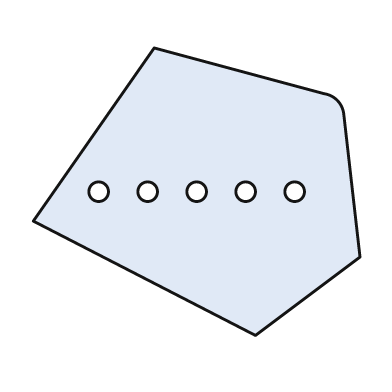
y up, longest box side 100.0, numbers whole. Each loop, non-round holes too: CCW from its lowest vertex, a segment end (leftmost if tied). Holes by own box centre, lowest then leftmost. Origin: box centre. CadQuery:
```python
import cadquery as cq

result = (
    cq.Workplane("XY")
    .moveTo(18.0, -44.0)
    .lineTo(50.0, -20.0)
    .lineTo(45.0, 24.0)
    .threePointArc((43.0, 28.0), (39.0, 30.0))
    .lineTo(-13.0, 44.0)
    .lineTo(-50.0, -9.0)
    .close()
    .moveTo(-30.0, 0.0)
    .circle(3.0)
    .moveTo(-15.0, 0.0)
    .circle(3.0)
    .moveTo(0.0, 0.0)
    .circle(3.0)
    .moveTo(15.0, 0.0)
    .circle(3.0)
    .moveTo(30.0, 0.0)
    .circle(3.0)
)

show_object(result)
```